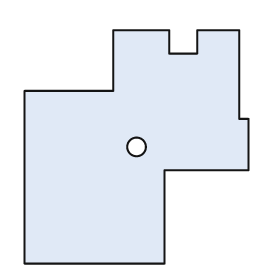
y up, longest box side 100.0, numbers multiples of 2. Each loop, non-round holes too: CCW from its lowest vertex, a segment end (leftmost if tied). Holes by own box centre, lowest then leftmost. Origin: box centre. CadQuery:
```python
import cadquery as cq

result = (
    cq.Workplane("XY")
    .moveTo(-48.0, -50.0)
    .lineTo(12.0, -50.0)
    .lineTo(12.0, -10.0)
    .lineTo(48.0, -10.0)
    .lineTo(48.0, 12.0)
    .lineTo(44.0, 12.0)
    .lineTo(44.0, 50.0)
    .lineTo(26.0, 50.0)
    .lineTo(26.0, 40.0)
    .lineTo(14.0, 40.0)
    .lineTo(14.0, 50.0)
    .lineTo(-10.0, 50.0)
    .lineTo(-10.0, 24.0)
    .lineTo(-48.0, 24.0)
    .close()
    .moveTo(0.0, 0.0)
    .circle(4.0)
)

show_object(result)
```